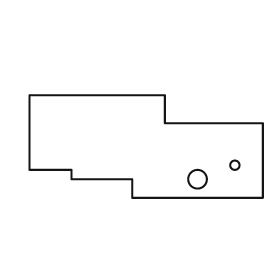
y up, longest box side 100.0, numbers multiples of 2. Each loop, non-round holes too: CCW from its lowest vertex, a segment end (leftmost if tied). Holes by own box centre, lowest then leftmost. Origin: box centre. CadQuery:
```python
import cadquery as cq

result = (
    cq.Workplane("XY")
    .moveTo(-6.0, -22.0)
    .lineTo(50.0, -22.0)
    .lineTo(50.0, 10.0)
    .lineTo(8.0, 10.0)
    .lineTo(8.0, 22.0)
    .lineTo(-50.0, 22.0)
    .lineTo(-50.0, -10.0)
    .lineTo(-32.0, -10.0)
    .lineTo(-32.0, -14.0)
    .lineTo(-6.0, -14.0)
    .close()
    .moveTo(22.0, -14.0)
    .circle(4.0)
    .moveTo(38.0, -8.0)
    .circle(2.0)
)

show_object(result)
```